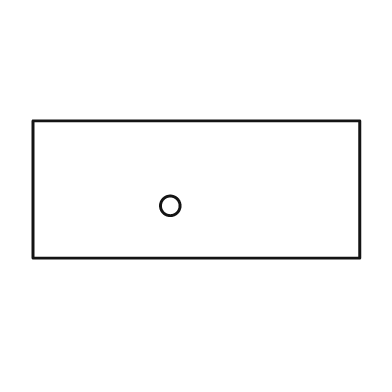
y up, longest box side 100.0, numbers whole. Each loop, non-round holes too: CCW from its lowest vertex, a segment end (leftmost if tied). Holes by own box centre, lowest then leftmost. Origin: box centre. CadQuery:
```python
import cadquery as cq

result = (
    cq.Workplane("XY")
    .moveTo(-50.0, -21.0)
    .lineTo(50.0, -21.0)
    .lineTo(50.0, 21.0)
    .lineTo(-50.0, 21.0)
    .close()
    .moveTo(-8.0, -5.0)
    .circle(3.0)
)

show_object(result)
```